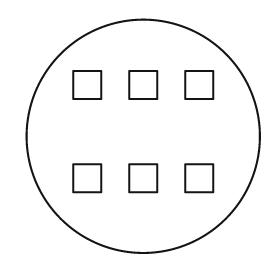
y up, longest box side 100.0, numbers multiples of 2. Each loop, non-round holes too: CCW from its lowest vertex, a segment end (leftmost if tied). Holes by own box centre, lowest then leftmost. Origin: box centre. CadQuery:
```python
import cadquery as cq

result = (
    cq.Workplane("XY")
    .moveTo(0.0, 0.0)
    .circle(50.0)
    .moveTo(-30.0, -24.0)
    .lineTo(-18.0, -24.0)
    .lineTo(-18.0, -12.0)
    .lineTo(-30.0, -12.0)
    .close()
    .moveTo(-6.0, -24.0)
    .lineTo(6.0, -24.0)
    .lineTo(6.0, -12.0)
    .lineTo(-6.0, -12.0)
    .close()
    .moveTo(18.0, -24.0)
    .lineTo(30.0, -24.0)
    .lineTo(30.0, -12.0)
    .lineTo(18.0, -12.0)
    .close()
    .moveTo(-30.0, 16.0)
    .lineTo(-18.0, 16.0)
    .lineTo(-18.0, 28.0)
    .lineTo(-30.0, 28.0)
    .close()
    .moveTo(-6.0, 16.0)
    .lineTo(6.0, 16.0)
    .lineTo(6.0, 28.0)
    .lineTo(-6.0, 28.0)
    .close()
    .moveTo(18.0, 16.0)
    .lineTo(30.0, 16.0)
    .lineTo(30.0, 28.0)
    .lineTo(18.0, 28.0)
    .close()
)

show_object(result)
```